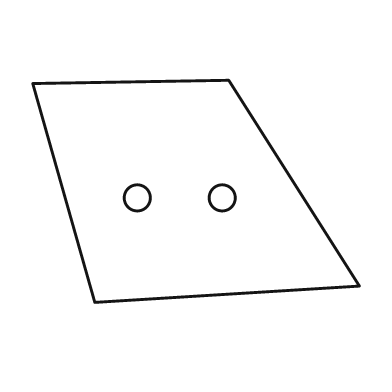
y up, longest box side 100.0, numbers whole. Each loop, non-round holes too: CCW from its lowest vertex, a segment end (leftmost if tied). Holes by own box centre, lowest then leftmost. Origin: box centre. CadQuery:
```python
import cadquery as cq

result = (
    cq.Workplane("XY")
    .moveTo(-31.0, -34.0)
    .lineTo(50.0, -29.0)
    .lineTo(10.0, 34.0)
    .lineTo(-50.0, 33.0)
    .close()
    .moveTo(-18.0, -2.0)
    .circle(4.0)
    .moveTo(8.0, -2.0)
    .circle(4.0)
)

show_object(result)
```